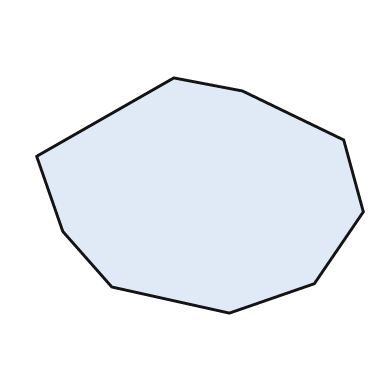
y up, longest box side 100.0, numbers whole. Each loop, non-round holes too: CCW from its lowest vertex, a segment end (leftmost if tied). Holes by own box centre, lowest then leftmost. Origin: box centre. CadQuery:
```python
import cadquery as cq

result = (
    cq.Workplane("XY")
    .moveTo(9.0, -36.0)
    .lineTo(35.0, -27.0)
    .lineTo(50.0, -5.0)
    .lineTo(44.0, 17.0)
    .lineTo(13.0, 32.0)
    .lineTo(-8.0, 36.0)
    .lineTo(-50.0, 12.0)
    .lineTo(-42.0, -11.0)
    .lineTo(-27.0, -28.0)
    .close()
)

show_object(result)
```